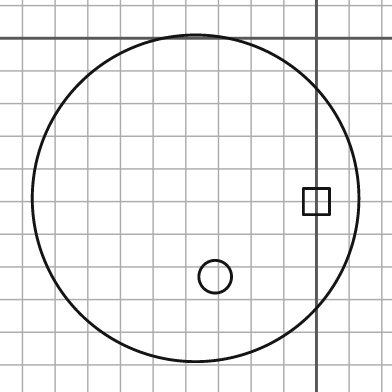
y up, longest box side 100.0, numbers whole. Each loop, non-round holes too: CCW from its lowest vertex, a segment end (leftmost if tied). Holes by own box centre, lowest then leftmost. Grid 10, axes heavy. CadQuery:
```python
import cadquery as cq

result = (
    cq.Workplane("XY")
    .moveTo(-37.0, -49.0)
    .circle(50.0)
    .moveTo(-31.0, -73.0)
    .circle(5.0)
    .moveTo(-4.0, -54.0)
    .lineTo(4.0, -54.0)
    .lineTo(4.0, -46.0)
    .lineTo(-4.0, -46.0)
    .close()
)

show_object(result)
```